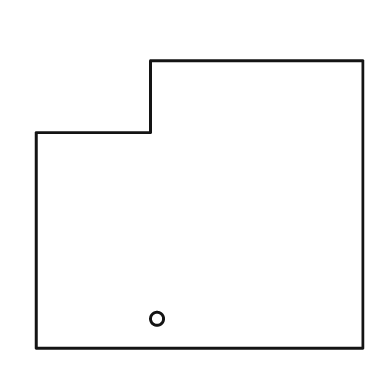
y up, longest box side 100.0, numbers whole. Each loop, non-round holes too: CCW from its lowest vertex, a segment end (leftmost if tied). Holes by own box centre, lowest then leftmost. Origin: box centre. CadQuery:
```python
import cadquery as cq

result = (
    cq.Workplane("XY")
    .moveTo(-50.0, -44.0)
    .lineTo(50.0, -44.0)
    .lineTo(50.0, 44.0)
    .lineTo(-15.0, 44.0)
    .lineTo(-15.0, 22.0)
    .lineTo(-50.0, 22.0)
    .close()
    .moveTo(-13.0, -35.0)
    .circle(2.0)
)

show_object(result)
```